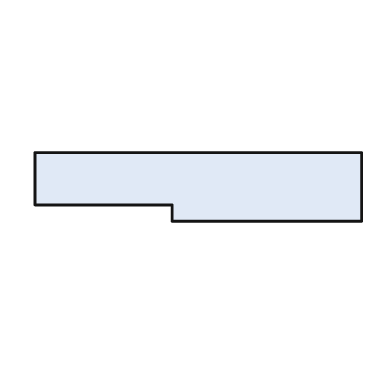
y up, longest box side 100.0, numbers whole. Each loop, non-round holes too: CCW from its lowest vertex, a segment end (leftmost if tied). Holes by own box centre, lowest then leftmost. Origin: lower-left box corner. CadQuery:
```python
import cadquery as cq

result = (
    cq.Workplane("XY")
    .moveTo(42.0, 0.0)
    .lineTo(100.0, 0.0)
    .lineTo(100.0, 21.0)
    .lineTo(0.0, 21.0)
    .lineTo(0.0, 5.0)
    .lineTo(42.0, 5.0)
    .close()
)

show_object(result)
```